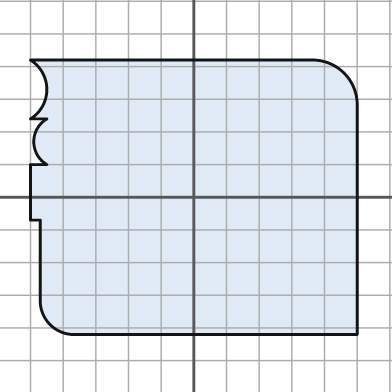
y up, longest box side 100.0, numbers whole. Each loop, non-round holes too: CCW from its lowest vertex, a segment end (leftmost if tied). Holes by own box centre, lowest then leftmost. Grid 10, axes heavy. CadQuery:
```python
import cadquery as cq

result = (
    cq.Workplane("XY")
    .moveTo(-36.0, -42.0)
    .lineTo(50.0, -42.0)
    .lineTo(50.0, 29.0)
    .threePointArc((46.0, 38.0), (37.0, 42.0))
    .lineTo(-50.0, 42.0)
    .threePointArc((-45.0, 33.0), (-50.0, 24.0))
    .lineTo(-45.0, 24.0)
    .threePointArc((-49.0, 17.0), (-45.0, 10.0))
    .lineTo(-50.0, 10.0)
    .lineTo(-50.0, -7.0)
    .lineTo(-47.0, -7.0)
    .lineTo(-47.0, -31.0)
    .threePointArc((-44.0, -39.0), (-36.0, -42.0))
    .close()
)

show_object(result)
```